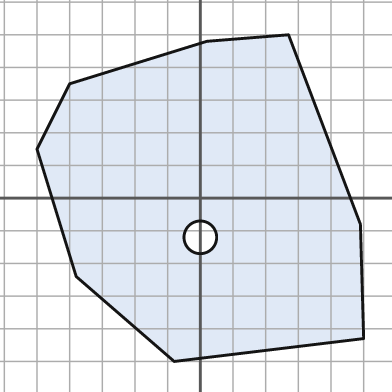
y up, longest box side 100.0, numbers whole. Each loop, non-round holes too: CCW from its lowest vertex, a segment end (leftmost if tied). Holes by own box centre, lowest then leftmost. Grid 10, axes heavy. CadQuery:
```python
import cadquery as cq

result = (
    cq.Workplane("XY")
    .moveTo(-8.0, -50.0)
    .lineTo(50.0, -43.0)
    .lineTo(49.0, -8.0)
    .lineTo(27.0, 50.0)
    .lineTo(2.0, 48.0)
    .lineTo(-40.0, 35.0)
    .lineTo(-50.0, 15.0)
    .lineTo(-38.0, -24.0)
    .close()
    .moveTo(0.0, -12.0)
    .circle(5.0)
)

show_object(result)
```